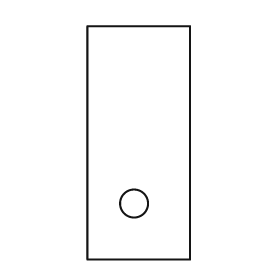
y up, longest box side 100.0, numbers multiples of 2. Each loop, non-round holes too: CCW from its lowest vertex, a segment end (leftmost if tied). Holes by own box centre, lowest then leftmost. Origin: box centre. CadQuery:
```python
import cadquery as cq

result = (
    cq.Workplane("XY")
    .moveTo(-22.0, -50.0)
    .lineTo(22.0, -50.0)
    .lineTo(22.0, 50.0)
    .lineTo(-22.0, 50.0)
    .close()
    .moveTo(-2.0, -26.0)
    .circle(6.0)
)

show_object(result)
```